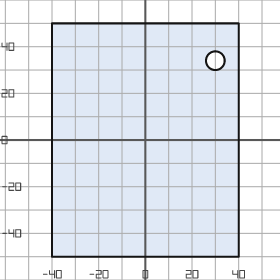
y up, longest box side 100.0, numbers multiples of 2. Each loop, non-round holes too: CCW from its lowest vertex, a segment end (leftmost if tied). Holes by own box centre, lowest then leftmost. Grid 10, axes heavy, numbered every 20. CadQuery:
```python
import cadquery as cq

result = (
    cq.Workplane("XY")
    .moveTo(-40.0, -50.0)
    .lineTo(40.0, -50.0)
    .lineTo(40.0, 50.0)
    .lineTo(-40.0, 50.0)
    .close()
    .moveTo(30.0, 34.0)
    .circle(4.0)
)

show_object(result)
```